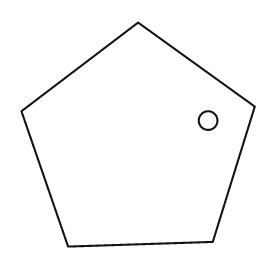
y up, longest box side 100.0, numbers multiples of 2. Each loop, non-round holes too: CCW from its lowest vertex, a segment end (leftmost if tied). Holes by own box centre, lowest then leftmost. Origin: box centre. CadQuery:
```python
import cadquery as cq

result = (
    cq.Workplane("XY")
    .moveTo(-30.0, -48.0)
    .lineTo(32.0, -46.0)
    .lineTo(50.0, 12.0)
    .lineTo(0.0, 48.0)
    .lineTo(-50.0, 10.0)
    .close()
    .moveTo(30.0, 6.0)
    .circle(4.0)
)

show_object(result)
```